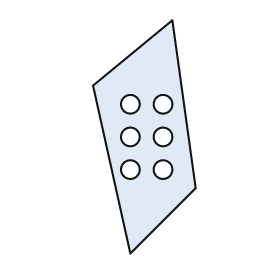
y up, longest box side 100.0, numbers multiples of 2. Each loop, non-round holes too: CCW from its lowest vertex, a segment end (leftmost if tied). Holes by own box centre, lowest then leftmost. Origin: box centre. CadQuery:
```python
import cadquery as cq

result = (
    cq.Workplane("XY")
    .moveTo(-6.0, -50.0)
    .lineTo(22.0, -22.0)
    .lineTo(12.0, 50.0)
    .lineTo(-22.0, 22.0)
    .close()
    .moveTo(-6.0, -14.0)
    .circle(4.0)
    .moveTo(8.0, -14.0)
    .circle(4.0)
    .moveTo(-6.0, 0.0)
    .circle(4.0)
    .moveTo(8.0, 0.0)
    .circle(4.0)
    .moveTo(-6.0, 14.0)
    .circle(4.0)
    .moveTo(8.0, 14.0)
    .circle(4.0)
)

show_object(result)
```